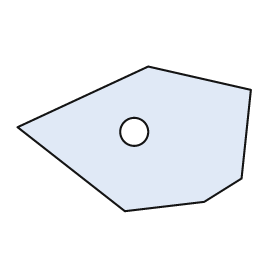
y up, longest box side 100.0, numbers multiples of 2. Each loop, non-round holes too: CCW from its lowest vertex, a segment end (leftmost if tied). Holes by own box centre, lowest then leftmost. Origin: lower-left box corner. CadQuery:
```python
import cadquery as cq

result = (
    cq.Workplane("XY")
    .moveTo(46.0, 0.0)
    .lineTo(80.0, 4.0)
    .lineTo(96.0, 14.0)
    .lineTo(100.0, 52.0)
    .lineTo(56.0, 62.0)
    .lineTo(0.0, 36.0)
    .close()
    .moveTo(50.0, 34.0)
    .circle(6.0)
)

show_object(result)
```